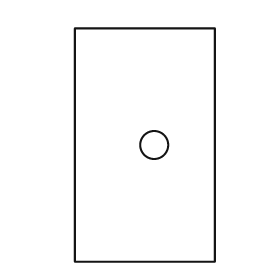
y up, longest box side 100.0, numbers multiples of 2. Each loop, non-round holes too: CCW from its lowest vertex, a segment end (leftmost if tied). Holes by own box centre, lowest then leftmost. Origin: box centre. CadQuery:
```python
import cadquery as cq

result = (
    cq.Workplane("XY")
    .moveTo(-30.0, -50.0)
    .lineTo(30.0, -50.0)
    .lineTo(30.0, 50.0)
    .lineTo(-30.0, 50.0)
    .close()
    .moveTo(4.0, 0.0)
    .circle(6.0)
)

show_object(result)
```